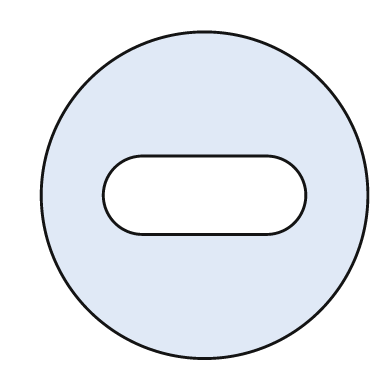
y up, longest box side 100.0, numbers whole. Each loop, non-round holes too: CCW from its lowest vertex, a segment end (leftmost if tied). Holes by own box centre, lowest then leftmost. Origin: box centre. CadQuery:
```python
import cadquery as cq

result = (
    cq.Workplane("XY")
    .moveTo(0.0, 0.0)
    .circle(50.0)
    .moveTo(-19.0, -12.0)
    .lineTo(19.0, -12.0)
    .threePointArc((31.0, 0.0), (19.0, 12.0))
    .lineTo(-19.0, 12.0)
    .threePointArc((-31.0, 0.0), (-19.0, -12.0))
    .close()
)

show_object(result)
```